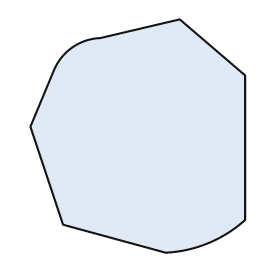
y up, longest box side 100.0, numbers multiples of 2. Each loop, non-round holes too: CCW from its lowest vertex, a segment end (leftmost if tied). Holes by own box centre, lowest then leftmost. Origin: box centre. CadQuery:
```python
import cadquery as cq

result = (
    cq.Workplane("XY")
    .moveTo(12.0, -50.0)
    .threePointArc((30.0, -46.0), (46.0, -36.0))
    .lineTo(46.0, 26.0)
    .lineTo(18.0, 50.0)
    .lineTo(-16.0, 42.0)
    .threePointArc((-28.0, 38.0), (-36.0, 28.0))
    .lineTo(-46.0, 4.0)
    .lineTo(-32.0, -38.0)
    .close()
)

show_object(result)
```